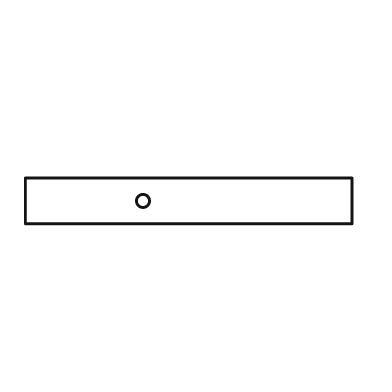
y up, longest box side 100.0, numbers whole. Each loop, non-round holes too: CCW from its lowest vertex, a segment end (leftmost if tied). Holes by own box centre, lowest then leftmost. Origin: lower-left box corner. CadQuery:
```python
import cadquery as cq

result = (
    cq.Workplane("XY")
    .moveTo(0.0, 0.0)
    .lineTo(100.0, 0.0)
    .lineTo(100.0, 14.0)
    .lineTo(0.0, 14.0)
    .close()
    .moveTo(36.0, 7.0)
    .circle(2.0)
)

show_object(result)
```